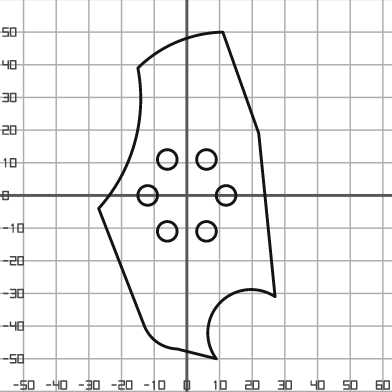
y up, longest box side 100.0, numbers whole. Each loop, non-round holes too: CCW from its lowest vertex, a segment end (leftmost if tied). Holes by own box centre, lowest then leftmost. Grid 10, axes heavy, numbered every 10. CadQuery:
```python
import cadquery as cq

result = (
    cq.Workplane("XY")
    .moveTo(9.0, -50.0)
    .threePointArc((10.0, -33.0), (27.0, -31.0))
    .lineTo(22.0, 19.0)
    .lineTo(11.0, 50.0)
    .threePointArc((-3.0, 47.0), (-15.0, 39.0))
    .threePointArc((-16.0, 16.0), (-27.0, -4.0))
    .lineTo(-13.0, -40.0)
    .threePointArc((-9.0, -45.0), (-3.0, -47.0))
    .close()
    .moveTo(-6.0, -11.0)
    .circle(3.0)
    .moveTo(6.0, -11.0)
    .circle(3.0)
    .moveTo(-12.0, 0.0)
    .circle(3.0)
    .moveTo(12.0, 0.0)
    .circle(3.0)
    .moveTo(-6.0, 11.0)
    .circle(3.0)
    .moveTo(6.0, 11.0)
    .circle(3.0)
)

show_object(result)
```